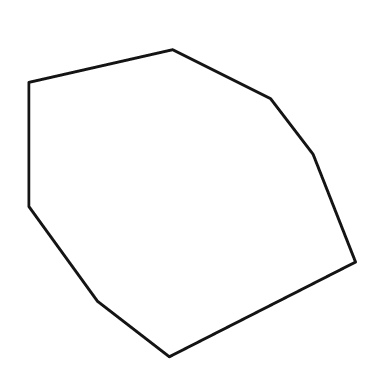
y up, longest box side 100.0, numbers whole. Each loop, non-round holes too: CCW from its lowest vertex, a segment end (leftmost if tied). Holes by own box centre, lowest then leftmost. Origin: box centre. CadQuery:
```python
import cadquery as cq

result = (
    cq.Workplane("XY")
    .moveTo(-7.0, -47.0)
    .lineTo(50.0, -18.0)
    .lineTo(37.0, 15.0)
    .lineTo(24.0, 32.0)
    .lineTo(-6.0, 47.0)
    .lineTo(-50.0, 37.0)
    .lineTo(-50.0, -1.0)
    .lineTo(-29.0, -30.0)
    .close()
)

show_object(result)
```